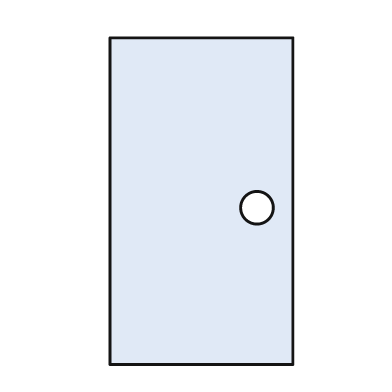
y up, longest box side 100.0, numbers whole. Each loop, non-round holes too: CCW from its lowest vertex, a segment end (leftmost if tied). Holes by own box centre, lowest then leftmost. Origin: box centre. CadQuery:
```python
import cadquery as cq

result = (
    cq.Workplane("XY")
    .moveTo(-28.0, -50.0)
    .lineTo(28.0, -50.0)
    .lineTo(28.0, 50.0)
    .lineTo(-28.0, 50.0)
    .close()
    .moveTo(17.0, -2.0)
    .circle(5.0)
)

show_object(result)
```